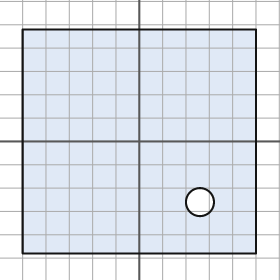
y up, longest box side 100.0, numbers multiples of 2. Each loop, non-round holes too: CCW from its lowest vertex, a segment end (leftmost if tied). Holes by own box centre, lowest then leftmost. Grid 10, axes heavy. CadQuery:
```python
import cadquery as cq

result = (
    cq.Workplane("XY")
    .moveTo(-50.0, -48.0)
    .lineTo(50.0, -48.0)
    .lineTo(50.0, 48.0)
    .lineTo(-50.0, 48.0)
    .close()
    .moveTo(26.0, -26.0)
    .circle(6.0)
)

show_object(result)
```